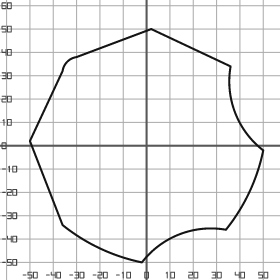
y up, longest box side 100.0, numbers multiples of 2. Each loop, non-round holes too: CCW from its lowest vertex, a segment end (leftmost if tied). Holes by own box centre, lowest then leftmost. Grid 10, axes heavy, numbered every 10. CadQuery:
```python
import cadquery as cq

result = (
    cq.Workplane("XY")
    .moveTo(-2.0, -50.0)
    .threePointArc((14.0, -38.0), (34.0, -36.0))
    .threePointArc((44.0, -20.0), (50.0, -2.0))
    .threePointArc((38.0, 14.0), (36.0, 34.0))
    .lineTo(2.0, 50.0)
    .lineTo(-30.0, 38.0)
    .threePointArc((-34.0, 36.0), (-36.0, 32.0))
    .lineTo(-50.0, 2.0)
    .lineTo(-36.0, -34.0)
    .threePointArc((-20.0, -44.0), (-2.0, -50.0))
    .close()
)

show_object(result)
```